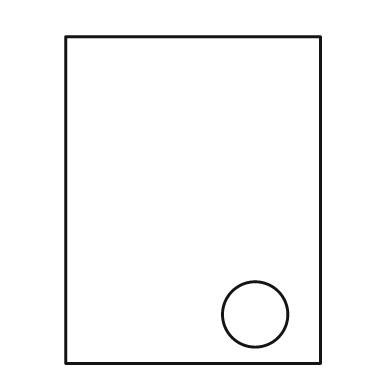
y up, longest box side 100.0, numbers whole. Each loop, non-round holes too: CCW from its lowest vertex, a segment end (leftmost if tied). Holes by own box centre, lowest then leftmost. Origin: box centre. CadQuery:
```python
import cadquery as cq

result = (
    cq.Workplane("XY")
    .moveTo(-39.0, -50.0)
    .lineTo(39.0, -50.0)
    .lineTo(39.0, 50.0)
    .lineTo(-39.0, 50.0)
    .close()
    .moveTo(19.0, -35.0)
    .circle(10.0)
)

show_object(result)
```